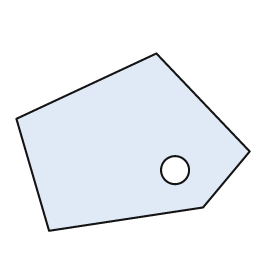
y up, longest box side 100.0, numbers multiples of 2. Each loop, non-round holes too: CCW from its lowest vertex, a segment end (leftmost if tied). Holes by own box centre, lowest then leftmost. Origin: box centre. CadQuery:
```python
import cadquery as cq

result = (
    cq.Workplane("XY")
    .moveTo(-36.0, -38.0)
    .lineTo(30.0, -28.0)
    .lineTo(50.0, -4.0)
    .lineTo(10.0, 38.0)
    .lineTo(-50.0, 10.0)
    .close()
    .moveTo(18.0, -12.0)
    .circle(6.0)
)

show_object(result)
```